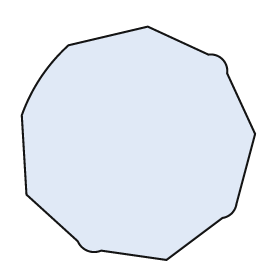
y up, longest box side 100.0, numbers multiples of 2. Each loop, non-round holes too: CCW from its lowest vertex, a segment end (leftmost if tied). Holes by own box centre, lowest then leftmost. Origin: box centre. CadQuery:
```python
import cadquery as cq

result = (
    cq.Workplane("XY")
    .moveTo(12.0, -50.0)
    .lineTo(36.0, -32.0)
    .threePointArc((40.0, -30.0), (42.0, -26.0))
    .lineTo(50.0, 4.0)
    .lineTo(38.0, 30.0)
    .threePointArc((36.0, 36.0), (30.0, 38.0))
    .lineTo(4.0, 50.0)
    .lineTo(-30.0, 42.0)
    .threePointArc((-42.0, 28.0), (-50.0, 12.0))
    .lineTo(-48.0, -22.0)
    .lineTo(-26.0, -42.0)
    .threePointArc((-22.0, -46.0), (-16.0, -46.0))
    .close()
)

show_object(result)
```